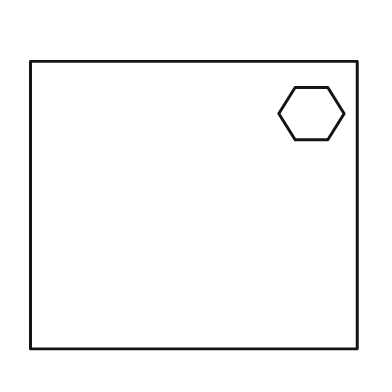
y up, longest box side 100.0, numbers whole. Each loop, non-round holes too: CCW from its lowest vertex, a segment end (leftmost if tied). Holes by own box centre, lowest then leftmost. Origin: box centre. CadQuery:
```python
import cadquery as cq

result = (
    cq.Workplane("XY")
    .moveTo(-50.0, -44.0)
    .lineTo(50.0, -44.0)
    .lineTo(50.0, 44.0)
    .lineTo(-50.0, 44.0)
    .close()
    .moveTo(31.0, 20.0)
    .lineTo(41.0, 20.0)
    .lineTo(46.0, 28.0)
    .lineTo(41.0, 36.0)
    .lineTo(31.0, 36.0)
    .lineTo(26.0, 28.0)
    .close()
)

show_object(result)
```